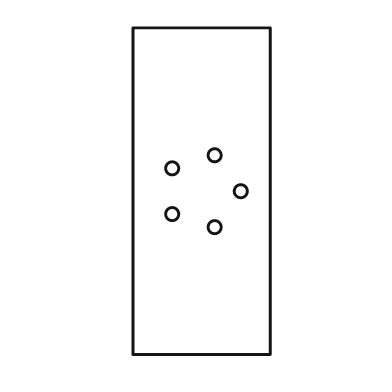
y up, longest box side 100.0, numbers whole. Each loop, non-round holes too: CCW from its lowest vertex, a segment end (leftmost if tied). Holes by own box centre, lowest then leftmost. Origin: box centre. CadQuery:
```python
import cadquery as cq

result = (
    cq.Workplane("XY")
    .moveTo(-21.0, -50.0)
    .lineTo(21.0, -50.0)
    .lineTo(21.0, 50.0)
    .lineTo(-21.0, 50.0)
    .close()
    .moveTo(4.0, -11.0)
    .circle(2.0)
    .moveTo(-9.0, -7.0)
    .circle(2.0)
    .moveTo(12.0, 0.0)
    .circle(2.0)
    .moveTo(-9.0, 7.0)
    .circle(2.0)
    .moveTo(4.0, 11.0)
    .circle(2.0)
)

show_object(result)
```